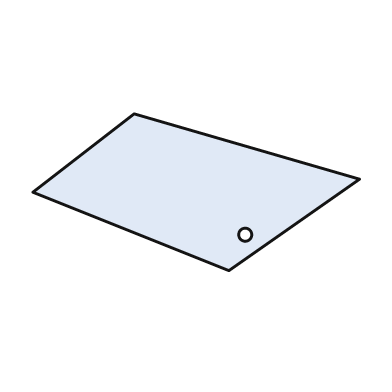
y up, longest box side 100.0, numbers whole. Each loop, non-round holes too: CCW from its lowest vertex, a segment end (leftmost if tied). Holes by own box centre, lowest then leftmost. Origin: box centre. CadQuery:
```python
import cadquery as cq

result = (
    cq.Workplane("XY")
    .moveTo(10.0, -24.0)
    .lineTo(50.0, 4.0)
    .lineTo(-19.0, 24.0)
    .lineTo(-50.0, 0.0)
    .close()
    .moveTo(15.0, -13.0)
    .circle(2.0)
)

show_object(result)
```